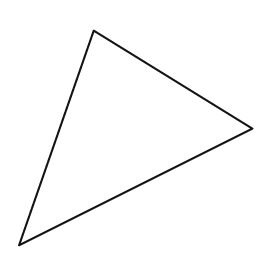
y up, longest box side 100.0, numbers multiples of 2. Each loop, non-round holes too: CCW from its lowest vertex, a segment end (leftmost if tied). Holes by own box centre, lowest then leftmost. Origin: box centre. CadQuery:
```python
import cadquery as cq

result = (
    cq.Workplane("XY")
    .moveTo(-50.0, -46.0)
    .lineTo(50.0, 4.0)
    .lineTo(-18.0, 46.0)
    .close()
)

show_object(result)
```